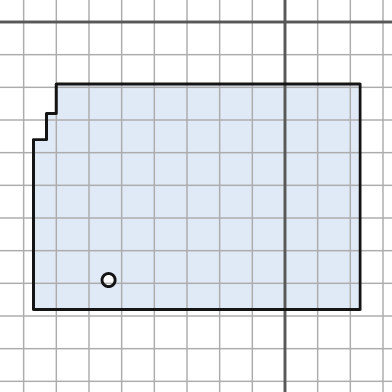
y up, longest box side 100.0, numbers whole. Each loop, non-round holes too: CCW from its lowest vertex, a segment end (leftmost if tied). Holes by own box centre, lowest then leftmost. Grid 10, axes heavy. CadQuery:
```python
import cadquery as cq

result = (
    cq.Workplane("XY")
    .moveTo(-77.0, -88.0)
    .lineTo(23.0, -88.0)
    .lineTo(23.0, -19.0)
    .lineTo(-70.0, -19.0)
    .lineTo(-70.0, -28.0)
    .lineTo(-73.0, -28.0)
    .lineTo(-73.0, -36.0)
    .lineTo(-77.0, -36.0)
    .close()
    .moveTo(-54.0, -79.0)
    .circle(2.0)
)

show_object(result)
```